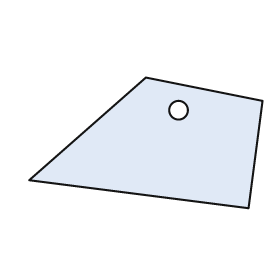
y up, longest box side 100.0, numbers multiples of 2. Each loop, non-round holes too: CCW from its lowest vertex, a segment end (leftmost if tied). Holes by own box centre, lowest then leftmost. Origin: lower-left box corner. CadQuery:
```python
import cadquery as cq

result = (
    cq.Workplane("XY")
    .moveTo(94.0, 0.0)
    .lineTo(100.0, 46.0)
    .lineTo(50.0, 56.0)
    .lineTo(0.0, 12.0)
    .close()
    .moveTo(64.0, 42.0)
    .circle(4.0)
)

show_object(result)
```